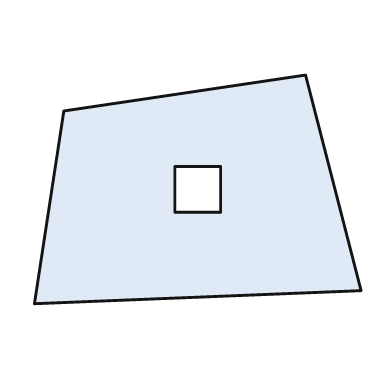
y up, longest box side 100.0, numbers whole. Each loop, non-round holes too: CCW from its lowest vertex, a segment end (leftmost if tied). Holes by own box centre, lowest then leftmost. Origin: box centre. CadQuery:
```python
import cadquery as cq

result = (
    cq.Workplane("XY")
    .moveTo(-50.0, -35.0)
    .lineTo(50.0, -31.0)
    .lineTo(33.0, 35.0)
    .lineTo(-41.0, 24.0)
    .close()
    .moveTo(-7.0, -7.0)
    .lineTo(7.0, -7.0)
    .lineTo(7.0, 7.0)
    .lineTo(-7.0, 7.0)
    .close()
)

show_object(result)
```